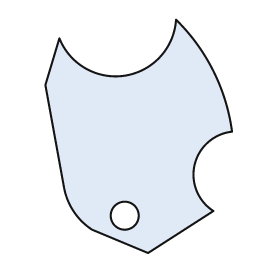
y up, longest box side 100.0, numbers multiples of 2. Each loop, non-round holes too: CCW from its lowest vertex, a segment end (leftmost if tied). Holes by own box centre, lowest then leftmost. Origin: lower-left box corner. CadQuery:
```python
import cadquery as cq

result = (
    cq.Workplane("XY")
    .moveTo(44.0, 0.0)
    .lineTo(72.0, 18.0)
    .threePointArc((64.0, 38.0), (80.0, 52.0))
    .threePointArc((72.0, 78.0), (56.0, 100.0))
    .threePointArc((34.0, 76.0), (6.0, 92.0))
    .lineTo(0.0, 72.0)
    .lineTo(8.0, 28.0)
    .threePointArc((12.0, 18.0), (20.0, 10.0))
    .close()
    .moveTo(34.0, 16.0)
    .circle(6.0)
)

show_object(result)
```